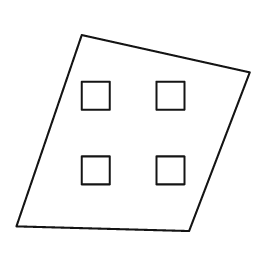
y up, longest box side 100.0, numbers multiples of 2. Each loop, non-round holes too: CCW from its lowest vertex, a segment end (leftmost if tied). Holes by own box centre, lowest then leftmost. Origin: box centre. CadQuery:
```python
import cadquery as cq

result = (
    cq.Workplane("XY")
    .moveTo(24.0, -42.0)
    .lineTo(50.0, 26.0)
    .lineTo(-22.0, 42.0)
    .lineTo(-50.0, -40.0)
    .close()
    .moveTo(-22.0, -22.0)
    .lineTo(-10.0, -22.0)
    .lineTo(-10.0, -10.0)
    .lineTo(-22.0, -10.0)
    .close()
    .moveTo(10.0, -22.0)
    .lineTo(22.0, -22.0)
    .lineTo(22.0, -10.0)
    .lineTo(10.0, -10.0)
    .close()
    .moveTo(-22.0, 10.0)
    .lineTo(-10.0, 10.0)
    .lineTo(-10.0, 22.0)
    .lineTo(-22.0, 22.0)
    .close()
    .moveTo(10.0, 10.0)
    .lineTo(22.0, 10.0)
    .lineTo(22.0, 22.0)
    .lineTo(10.0, 22.0)
    .close()
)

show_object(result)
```